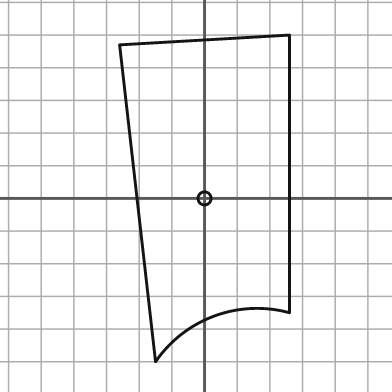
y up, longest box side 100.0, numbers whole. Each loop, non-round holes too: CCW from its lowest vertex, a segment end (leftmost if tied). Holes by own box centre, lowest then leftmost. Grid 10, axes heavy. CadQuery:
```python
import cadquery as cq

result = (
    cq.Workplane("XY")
    .moveTo(-15.0, -50.0)
    .threePointArc((3.0, -36.0), (26.0, -35.0))
    .lineTo(26.0, 50.0)
    .lineTo(-26.0, 47.0)
    .close()
    .moveTo(0.0, 0.0)
    .circle(2.0)
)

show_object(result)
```